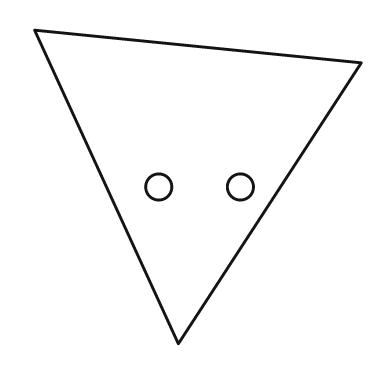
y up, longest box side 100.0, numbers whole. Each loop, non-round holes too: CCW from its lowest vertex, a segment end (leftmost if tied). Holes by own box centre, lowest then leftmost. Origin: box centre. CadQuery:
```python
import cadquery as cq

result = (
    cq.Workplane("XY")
    .moveTo(-6.0, -48.0)
    .lineTo(50.0, 38.0)
    .lineTo(-50.0, 48.0)
    .close()
    .moveTo(-12.0, 0.0)
    .circle(4.0)
    .moveTo(13.0, 0.0)
    .circle(4.0)
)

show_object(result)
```